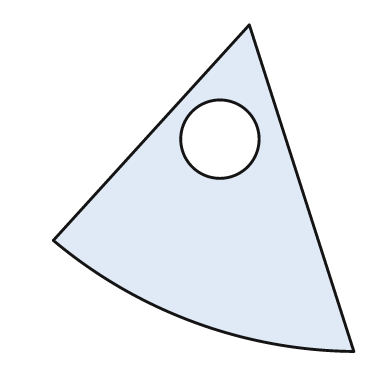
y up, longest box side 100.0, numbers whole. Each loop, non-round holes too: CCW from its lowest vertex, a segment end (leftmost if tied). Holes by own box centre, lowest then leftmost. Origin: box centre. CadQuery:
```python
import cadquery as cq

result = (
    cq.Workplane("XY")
    .moveTo(46.0, -50.0)
    .lineTo(14.0, 50.0)
    .lineTo(-46.0, -16.0)
    .threePointArc((-3.0, -41.0), (46.0, -50.0))
    .close()
    .moveTo(5.0, 15.0)
    .circle(12.0)
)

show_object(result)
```